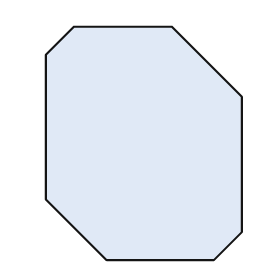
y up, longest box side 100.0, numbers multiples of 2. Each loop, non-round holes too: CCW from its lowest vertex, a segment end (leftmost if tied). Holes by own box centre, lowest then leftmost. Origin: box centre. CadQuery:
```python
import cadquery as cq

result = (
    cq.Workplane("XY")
    .moveTo(-16.0, -50.0)
    .lineTo(30.0, -50.0)
    .lineTo(42.0, -38.0)
    .lineTo(42.0, 20.0)
    .lineTo(12.0, 50.0)
    .lineTo(-30.0, 50.0)
    .lineTo(-42.0, 38.0)
    .lineTo(-42.0, -24.0)
    .close()
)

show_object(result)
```